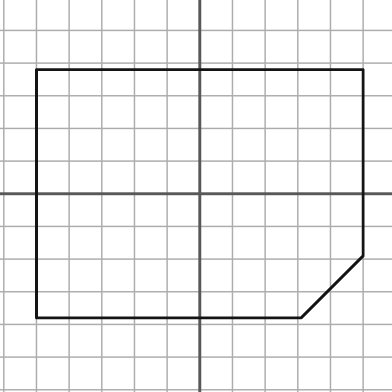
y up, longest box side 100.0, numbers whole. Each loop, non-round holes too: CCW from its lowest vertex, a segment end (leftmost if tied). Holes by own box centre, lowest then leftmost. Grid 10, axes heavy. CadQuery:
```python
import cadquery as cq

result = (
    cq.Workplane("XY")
    .moveTo(-50.0, -38.0)
    .lineTo(31.0, -38.0)
    .lineTo(50.0, -19.0)
    .lineTo(50.0, 38.0)
    .lineTo(-50.0, 38.0)
    .close()
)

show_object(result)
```